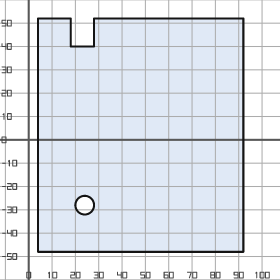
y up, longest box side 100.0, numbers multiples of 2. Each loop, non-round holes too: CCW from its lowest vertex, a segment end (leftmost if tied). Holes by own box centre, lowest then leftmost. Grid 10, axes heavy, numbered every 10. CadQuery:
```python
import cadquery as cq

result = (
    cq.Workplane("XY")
    .moveTo(4.0, -48.0)
    .lineTo(92.0, -48.0)
    .lineTo(92.0, 52.0)
    .lineTo(28.0, 52.0)
    .lineTo(28.0, 40.0)
    .lineTo(18.0, 40.0)
    .lineTo(18.0, 52.0)
    .lineTo(4.0, 52.0)
    .close()
    .moveTo(24.0, -28.0)
    .circle(4.0)
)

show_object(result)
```